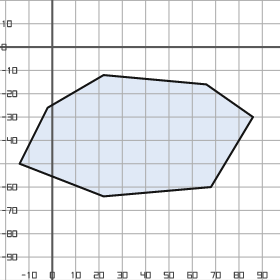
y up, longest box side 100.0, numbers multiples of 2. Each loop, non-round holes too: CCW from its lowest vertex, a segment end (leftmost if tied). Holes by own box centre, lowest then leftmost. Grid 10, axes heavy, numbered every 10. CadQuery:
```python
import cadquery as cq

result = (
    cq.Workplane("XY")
    .moveTo(22.0, -64.0)
    .lineTo(68.0, -60.0)
    .lineTo(86.0, -30.0)
    .lineTo(66.0, -16.0)
    .lineTo(22.0, -12.0)
    .lineTo(-2.0, -26.0)
    .lineTo(-14.0, -50.0)
    .close()
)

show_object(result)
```